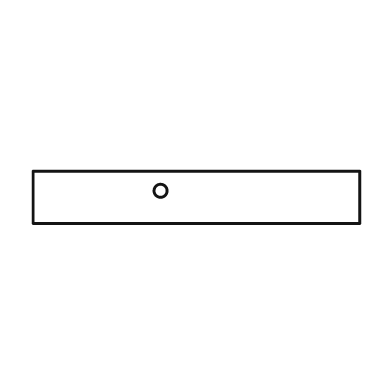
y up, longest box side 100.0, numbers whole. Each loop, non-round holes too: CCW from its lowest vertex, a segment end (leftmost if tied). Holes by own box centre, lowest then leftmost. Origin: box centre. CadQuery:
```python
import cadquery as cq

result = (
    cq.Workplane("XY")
    .moveTo(-50.0, -8.0)
    .lineTo(50.0, -8.0)
    .lineTo(50.0, 8.0)
    .lineTo(-50.0, 8.0)
    .close()
    .moveTo(-11.0, 2.0)
    .circle(2.0)
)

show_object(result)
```